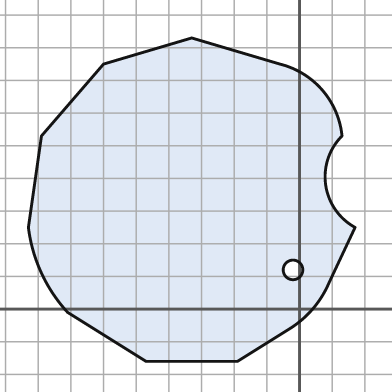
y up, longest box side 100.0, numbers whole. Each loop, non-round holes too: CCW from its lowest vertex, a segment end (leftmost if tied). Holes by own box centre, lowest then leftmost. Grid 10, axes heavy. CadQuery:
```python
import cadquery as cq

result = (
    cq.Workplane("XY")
    .moveTo(-47.0, -16.0)
    .lineTo(-19.0, -16.0)
    .lineTo(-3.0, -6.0)
    .threePointArc((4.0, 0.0), (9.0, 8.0))
    .lineTo(17.0, 25.0)
    .threePointArc((8.0, 38.0), (13.0, 53.0))
    .threePointArc((7.0, 67.0), (-6.0, 75.0))
    .lineTo(-33.0, 83.0)
    .lineTo(-60.0, 75.0)
    .lineTo(-79.0, 53.0)
    .lineTo(-83.0, 25.0)
    .threePointArc((-79.0, 11.0), (-71.0, -1.0))
    .close()
    .moveTo(-2.0, 12.0)
    .circle(3.0)
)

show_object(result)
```